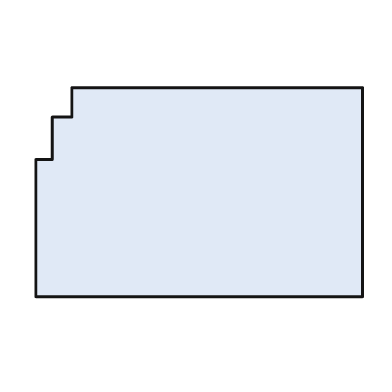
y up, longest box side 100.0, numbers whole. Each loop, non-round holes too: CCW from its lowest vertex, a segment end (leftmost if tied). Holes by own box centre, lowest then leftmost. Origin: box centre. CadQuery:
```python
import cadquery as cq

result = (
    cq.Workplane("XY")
    .moveTo(-50.0, -32.0)
    .lineTo(50.0, -32.0)
    .lineTo(50.0, 32.0)
    .lineTo(-39.0, 32.0)
    .lineTo(-39.0, 23.0)
    .lineTo(-45.0, 23.0)
    .lineTo(-45.0, 10.0)
    .lineTo(-50.0, 10.0)
    .close()
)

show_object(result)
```